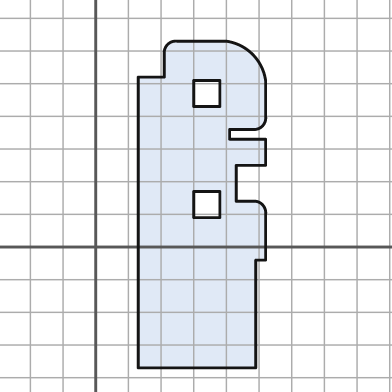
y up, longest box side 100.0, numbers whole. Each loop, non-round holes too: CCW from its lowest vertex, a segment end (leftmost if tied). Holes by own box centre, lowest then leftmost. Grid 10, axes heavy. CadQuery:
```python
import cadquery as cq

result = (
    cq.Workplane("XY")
    .moveTo(13.0, -37.0)
    .lineTo(49.0, -37.0)
    .lineTo(49.0, -4.0)
    .lineTo(52.0, -4.0)
    .lineTo(52.0, 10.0)
    .threePointArc((51.0, 13.0), (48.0, 14.0))
    .lineTo(43.0, 14.0)
    .lineTo(43.0, 25.0)
    .lineTo(52.0, 25.0)
    .lineTo(52.0, 33.0)
    .lineTo(41.0, 33.0)
    .lineTo(41.0, 36.0)
    .lineTo(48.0, 36.0)
    .threePointArc((51.0, 37.0), (52.0, 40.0))
    .lineTo(52.0, 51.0)
    .threePointArc((48.0, 59.0), (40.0, 63.0))
    .lineTo(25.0, 63.0)
    .threePointArc((22.0, 62.0), (21.0, 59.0))
    .lineTo(21.0, 52.0)
    .lineTo(13.0, 52.0)
    .close()
    .moveTo(30.0, 9.0)
    .lineTo(38.0, 9.0)
    .lineTo(38.0, 17.0)
    .lineTo(30.0, 17.0)
    .close()
    .moveTo(30.0, 43.0)
    .lineTo(38.0, 43.0)
    .lineTo(38.0, 51.0)
    .lineTo(30.0, 51.0)
    .close()
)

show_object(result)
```